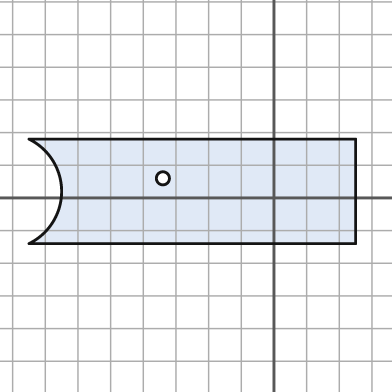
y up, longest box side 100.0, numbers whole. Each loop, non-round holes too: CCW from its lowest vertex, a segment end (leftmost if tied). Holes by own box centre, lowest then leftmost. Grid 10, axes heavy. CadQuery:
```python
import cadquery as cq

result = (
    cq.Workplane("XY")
    .moveTo(-75.0, -14.0)
    .lineTo(25.0, -14.0)
    .lineTo(25.0, 18.0)
    .lineTo(-75.0, 18.0)
    .threePointArc((-65.0, 2.0), (-75.0, -14.0))
    .close()
    .moveTo(-34.0, 6.0)
    .circle(2.0)
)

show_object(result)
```